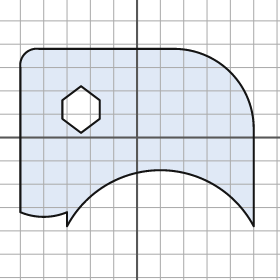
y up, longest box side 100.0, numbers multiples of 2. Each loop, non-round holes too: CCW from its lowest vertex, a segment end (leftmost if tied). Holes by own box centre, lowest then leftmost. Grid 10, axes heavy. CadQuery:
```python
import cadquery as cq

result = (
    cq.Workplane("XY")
    .moveTo(-30.0, -38.0)
    .threePointArc((10.0, -14.0), (50.0, -38.0))
    .lineTo(50.0, 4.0)
    .threePointArc((40.0, 28.0), (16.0, 38.0))
    .lineTo(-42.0, 38.0)
    .threePointArc((-48.0, 36.0), (-50.0, 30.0))
    .lineTo(-50.0, -32.0)
    .threePointArc((-40.0, -34.0), (-30.0, -32.0))
    .close()
    .moveTo(-24.0, 2.0)
    .lineTo(-16.0, 8.0)
    .lineTo(-16.0, 16.0)
    .lineTo(-24.0, 22.0)
    .lineTo(-32.0, 16.0)
    .lineTo(-32.0, 8.0)
    .close()
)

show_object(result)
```